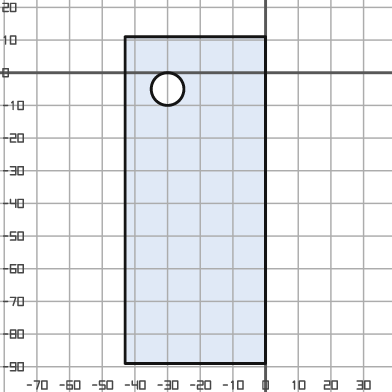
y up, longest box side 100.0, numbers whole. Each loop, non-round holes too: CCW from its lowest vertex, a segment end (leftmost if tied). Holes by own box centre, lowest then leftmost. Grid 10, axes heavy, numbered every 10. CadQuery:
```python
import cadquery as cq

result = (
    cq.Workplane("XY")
    .moveTo(-43.0, -89.0)
    .lineTo(0.0, -89.0)
    .lineTo(0.0, 11.0)
    .lineTo(-43.0, 11.0)
    .close()
    .moveTo(-30.0, -5.0)
    .circle(5.0)
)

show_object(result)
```